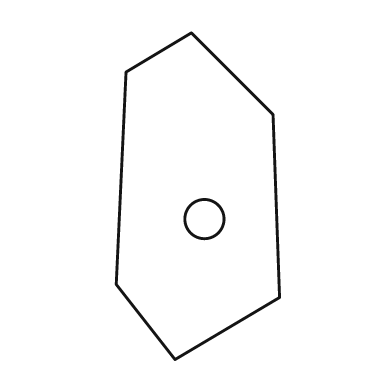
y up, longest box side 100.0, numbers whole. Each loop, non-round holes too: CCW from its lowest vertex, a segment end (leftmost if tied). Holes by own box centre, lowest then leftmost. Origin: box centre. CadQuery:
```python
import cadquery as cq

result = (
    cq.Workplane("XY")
    .moveTo(-7.0, -50.0)
    .lineTo(25.0, -31.0)
    .lineTo(23.0, 25.0)
    .lineTo(-2.0, 50.0)
    .lineTo(-22.0, 38.0)
    .lineTo(-25.0, -27.0)
    .close()
    .moveTo(2.0, -7.0)
    .circle(6.0)
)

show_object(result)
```